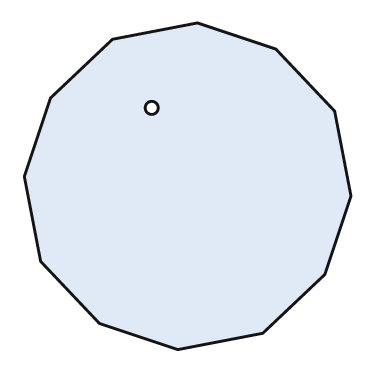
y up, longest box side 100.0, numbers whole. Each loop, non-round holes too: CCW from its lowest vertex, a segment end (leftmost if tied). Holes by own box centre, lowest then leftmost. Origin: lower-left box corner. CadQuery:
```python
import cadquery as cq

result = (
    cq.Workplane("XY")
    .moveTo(47.0, 0.0)
    .lineTo(73.0, 5.0)
    .lineTo(92.0, 23.0)
    .lineTo(100.0, 47.0)
    .lineTo(95.0, 73.0)
    .lineTo(77.0, 92.0)
    .lineTo(53.0, 100.0)
    .lineTo(27.0, 95.0)
    .lineTo(8.0, 77.0)
    .lineTo(0.0, 53.0)
    .lineTo(5.0, 27.0)
    .lineTo(23.0, 8.0)
    .close()
    .moveTo(39.0, 74.0)
    .circle(2.0)
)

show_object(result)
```